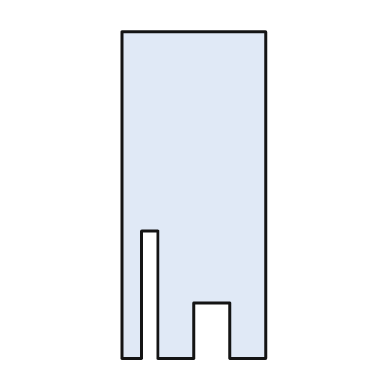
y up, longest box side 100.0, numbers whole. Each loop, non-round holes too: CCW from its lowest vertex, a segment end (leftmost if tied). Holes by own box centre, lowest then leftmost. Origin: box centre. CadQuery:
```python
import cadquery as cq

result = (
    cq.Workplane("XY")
    .moveTo(-22.0, -50.0)
    .lineTo(-16.0, -50.0)
    .lineTo(-16.0, -11.0)
    .lineTo(-11.0, -11.0)
    .lineTo(-11.0, -50.0)
    .lineTo(0.0, -50.0)
    .lineTo(0.0, -33.0)
    .lineTo(11.0, -33.0)
    .lineTo(11.0, -50.0)
    .lineTo(22.0, -50.0)
    .lineTo(22.0, 50.0)
    .lineTo(-22.0, 50.0)
    .close()
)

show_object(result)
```